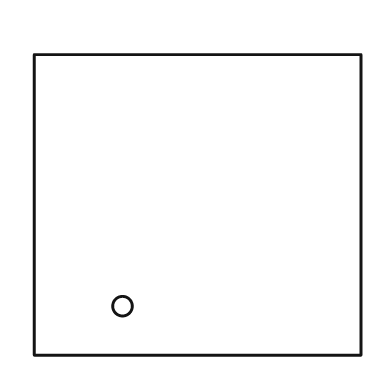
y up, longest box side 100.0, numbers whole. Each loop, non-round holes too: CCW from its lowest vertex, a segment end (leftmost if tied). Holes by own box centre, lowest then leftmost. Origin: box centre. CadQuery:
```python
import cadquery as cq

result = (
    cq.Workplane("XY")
    .moveTo(-50.0, -46.0)
    .lineTo(50.0, -46.0)
    .lineTo(50.0, 46.0)
    .lineTo(-50.0, 46.0)
    .close()
    .moveTo(-23.0, -31.0)
    .circle(3.0)
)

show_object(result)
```